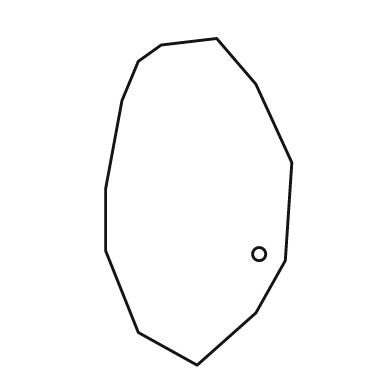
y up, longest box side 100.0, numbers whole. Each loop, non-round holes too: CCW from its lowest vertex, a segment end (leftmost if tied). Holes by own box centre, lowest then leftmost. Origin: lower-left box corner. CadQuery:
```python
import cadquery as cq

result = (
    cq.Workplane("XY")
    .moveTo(28.0, 0.0)
    .lineTo(46.0, 16.0)
    .lineTo(55.0, 32.0)
    .lineTo(57.0, 62.0)
    .lineTo(46.0, 86.0)
    .lineTo(34.0, 100.0)
    .lineTo(17.0, 98.0)
    .lineTo(10.0, 93.0)
    .lineTo(5.0, 81.0)
    .lineTo(0.0, 54.0)
    .lineTo(0.0, 35.0)
    .lineTo(10.0, 10.0)
    .close()
    .moveTo(47.0, 34.0)
    .circle(2.0)
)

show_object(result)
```